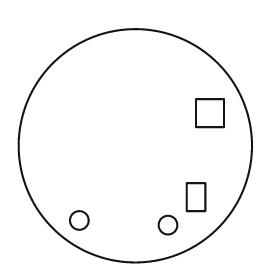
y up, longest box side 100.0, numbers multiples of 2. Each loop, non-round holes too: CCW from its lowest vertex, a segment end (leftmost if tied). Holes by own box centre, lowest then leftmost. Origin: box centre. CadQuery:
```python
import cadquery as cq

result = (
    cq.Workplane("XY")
    .moveTo(0.0, 0.0)
    .circle(50.0)
    .moveTo(14.0, -34.0)
    .circle(4.0)
    .moveTo(-24.0, -32.0)
    .circle(4.0)
    .moveTo(22.0, -28.0)
    .lineTo(30.0, -28.0)
    .lineTo(30.0, -16.0)
    .lineTo(22.0, -16.0)
    .close()
    .moveTo(26.0, 8.0)
    .lineTo(38.0, 8.0)
    .lineTo(38.0, 20.0)
    .lineTo(26.0, 20.0)
    .close()
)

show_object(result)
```